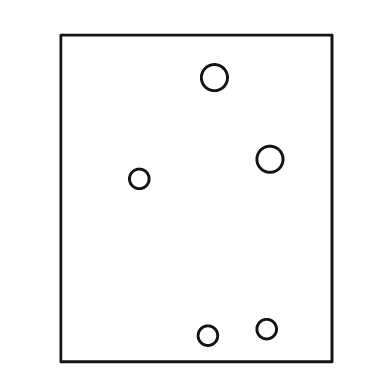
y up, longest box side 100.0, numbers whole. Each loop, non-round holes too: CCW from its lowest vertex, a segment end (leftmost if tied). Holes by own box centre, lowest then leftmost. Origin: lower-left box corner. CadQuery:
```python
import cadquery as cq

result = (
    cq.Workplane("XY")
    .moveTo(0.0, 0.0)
    .lineTo(83.0, 0.0)
    .lineTo(83.0, 100.0)
    .lineTo(0.0, 100.0)
    .close()
    .moveTo(45.0, 8.0)
    .circle(3.0)
    .moveTo(63.0, 10.0)
    .circle(3.0)
    .moveTo(24.0, 56.0)
    .circle(3.0)
    .moveTo(64.0, 62.0)
    .circle(4.0)
    .moveTo(47.0, 87.0)
    .circle(4.0)
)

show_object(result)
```